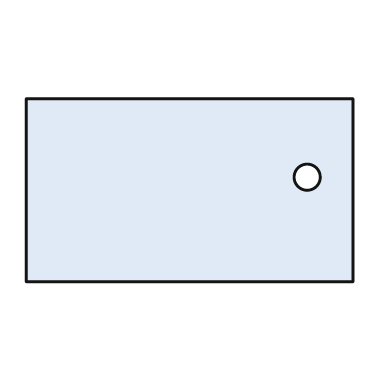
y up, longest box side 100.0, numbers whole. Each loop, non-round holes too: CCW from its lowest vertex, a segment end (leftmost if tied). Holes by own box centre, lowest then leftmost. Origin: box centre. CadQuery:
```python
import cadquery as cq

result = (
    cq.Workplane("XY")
    .moveTo(-50.0, -28.0)
    .lineTo(50.0, -28.0)
    .lineTo(50.0, 28.0)
    .lineTo(-50.0, 28.0)
    .close()
    .moveTo(36.0, 4.0)
    .circle(4.0)
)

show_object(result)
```